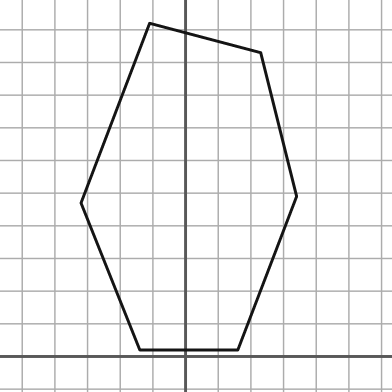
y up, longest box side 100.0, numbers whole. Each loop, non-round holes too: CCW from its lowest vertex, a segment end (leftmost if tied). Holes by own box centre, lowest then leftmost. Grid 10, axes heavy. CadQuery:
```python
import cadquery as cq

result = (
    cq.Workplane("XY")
    .moveTo(-14.0, 2.0)
    .lineTo(16.0, 2.0)
    .lineTo(34.0, 49.0)
    .lineTo(23.0, 93.0)
    .lineTo(-11.0, 102.0)
    .lineTo(-32.0, 47.0)
    .close()
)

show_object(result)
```